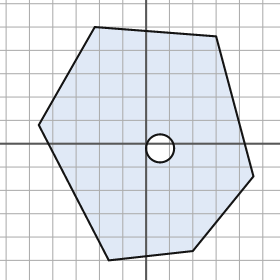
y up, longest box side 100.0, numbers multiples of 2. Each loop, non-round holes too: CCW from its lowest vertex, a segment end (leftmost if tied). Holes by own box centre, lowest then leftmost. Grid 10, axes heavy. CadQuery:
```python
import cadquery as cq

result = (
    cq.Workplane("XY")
    .moveTo(-16.0, -50.0)
    .lineTo(20.0, -46.0)
    .lineTo(46.0, -14.0)
    .lineTo(30.0, 46.0)
    .lineTo(-22.0, 50.0)
    .lineTo(-46.0, 8.0)
    .close()
    .moveTo(6.0, -2.0)
    .circle(6.0)
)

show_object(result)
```